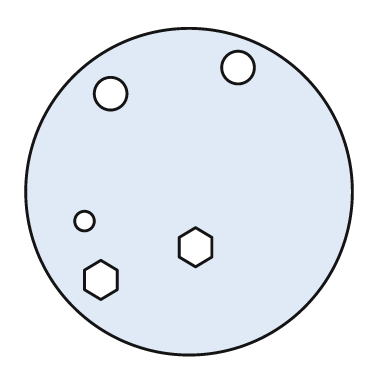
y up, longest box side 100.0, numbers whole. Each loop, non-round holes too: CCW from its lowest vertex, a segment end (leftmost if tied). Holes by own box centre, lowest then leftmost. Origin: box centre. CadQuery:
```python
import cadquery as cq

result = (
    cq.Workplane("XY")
    .moveTo(0.0, 0.0)
    .circle(50.0)
    .moveTo(-27.0, -33.0)
    .lineTo(-22.0, -30.0)
    .lineTo(-22.0, -24.0)
    .lineTo(-27.0, -21.0)
    .lineTo(-32.0, -24.0)
    .lineTo(-32.0, -30.0)
    .close()
    .moveTo(2.0, -23.0)
    .lineTo(7.0, -20.0)
    .lineTo(7.0, -14.0)
    .lineTo(2.0, -11.0)
    .lineTo(-3.0, -14.0)
    .lineTo(-3.0, -20.0)
    .close()
    .moveTo(-32.0, -9.0)
    .circle(3.0)
    .moveTo(-24.0, 30.0)
    .circle(5.0)
    .moveTo(15.0, 38.0)
    .circle(5.0)
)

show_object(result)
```